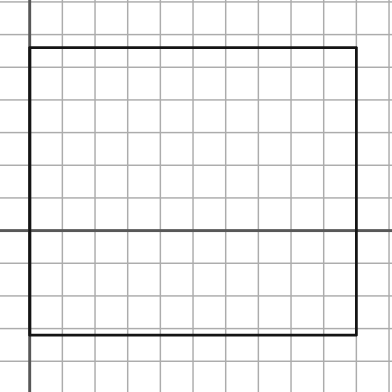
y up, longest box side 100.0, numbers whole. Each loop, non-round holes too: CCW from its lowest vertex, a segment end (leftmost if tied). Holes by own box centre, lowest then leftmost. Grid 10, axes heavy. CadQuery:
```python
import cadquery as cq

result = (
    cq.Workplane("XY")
    .moveTo(0.0, -32.0)
    .lineTo(100.0, -32.0)
    .lineTo(100.0, 56.0)
    .lineTo(0.0, 56.0)
    .close()
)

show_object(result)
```